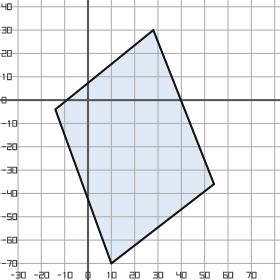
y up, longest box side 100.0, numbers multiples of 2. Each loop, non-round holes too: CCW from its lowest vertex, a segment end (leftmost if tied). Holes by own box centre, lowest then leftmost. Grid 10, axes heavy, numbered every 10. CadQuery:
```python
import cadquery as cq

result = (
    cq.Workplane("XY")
    .moveTo(10.0, -70.0)
    .lineTo(54.0, -36.0)
    .lineTo(28.0, 30.0)
    .lineTo(-14.0, -4.0)
    .close()
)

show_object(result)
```